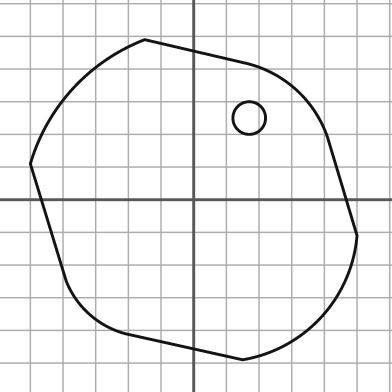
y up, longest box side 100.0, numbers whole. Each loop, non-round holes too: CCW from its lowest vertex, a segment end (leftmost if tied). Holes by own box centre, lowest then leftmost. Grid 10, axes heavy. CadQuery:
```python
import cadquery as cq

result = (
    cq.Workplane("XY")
    .moveTo(15.0, -49.0)
    .threePointArc((39.0, -36.0), (50.0, -11.0))
    .lineTo(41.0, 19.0)
    .threePointArc((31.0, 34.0), (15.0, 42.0))
    .lineTo(-15.0, 49.0)
    .threePointArc((-37.0, 34.0), (-50.0, 11.0))
    .lineTo(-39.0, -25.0)
    .threePointArc((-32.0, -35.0), (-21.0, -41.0))
    .close()
    .moveTo(17.0, 25.0)
    .circle(5.0)
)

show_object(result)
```